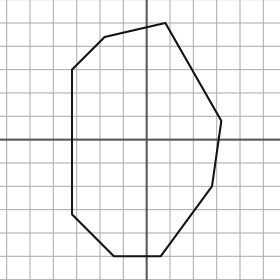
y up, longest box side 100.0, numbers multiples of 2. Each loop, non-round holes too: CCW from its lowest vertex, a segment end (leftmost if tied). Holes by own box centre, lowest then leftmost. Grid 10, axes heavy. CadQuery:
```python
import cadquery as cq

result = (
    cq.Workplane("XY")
    .moveTo(-14.0, -50.0)
    .lineTo(6.0, -50.0)
    .lineTo(28.0, -20.0)
    .lineTo(32.0, 8.0)
    .lineTo(8.0, 50.0)
    .lineTo(-18.0, 44.0)
    .lineTo(-32.0, 30.0)
    .lineTo(-32.0, -32.0)
    .close()
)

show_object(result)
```